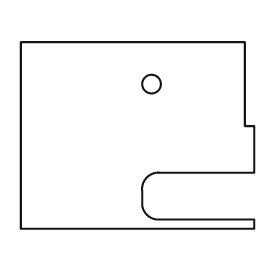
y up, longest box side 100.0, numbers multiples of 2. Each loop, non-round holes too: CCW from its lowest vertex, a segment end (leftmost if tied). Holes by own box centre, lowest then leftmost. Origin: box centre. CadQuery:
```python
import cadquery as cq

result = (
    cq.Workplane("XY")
    .moveTo(-50.0, -40.0)
    .lineTo(50.0, -40.0)
    .lineTo(50.0, -36.0)
    .lineTo(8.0, -36.0)
    .threePointArc((4.0, -34.0), (2.0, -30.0))
    .lineTo(2.0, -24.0)
    .threePointArc((4.0, -18.0), (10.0, -16.0))
    .lineTo(50.0, -16.0)
    .lineTo(50.0, 4.0)
    .lineTo(46.0, 4.0)
    .lineTo(46.0, 40.0)
    .lineTo(-50.0, 40.0)
    .close()
    .moveTo(6.0, 22.0)
    .circle(4.0)
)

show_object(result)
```